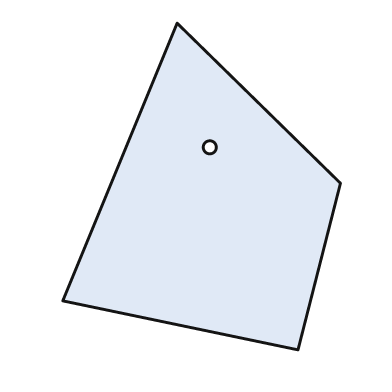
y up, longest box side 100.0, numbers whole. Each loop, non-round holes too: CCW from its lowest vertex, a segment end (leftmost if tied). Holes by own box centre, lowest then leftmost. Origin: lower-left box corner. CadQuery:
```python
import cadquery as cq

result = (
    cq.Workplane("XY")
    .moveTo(72.0, 0.0)
    .lineTo(85.0, 51.0)
    .lineTo(35.0, 100.0)
    .lineTo(0.0, 15.0)
    .close()
    .moveTo(45.0, 62.0)
    .circle(2.0)
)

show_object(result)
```